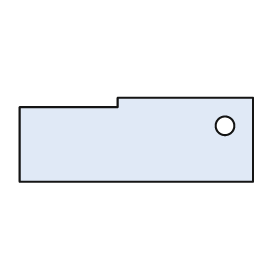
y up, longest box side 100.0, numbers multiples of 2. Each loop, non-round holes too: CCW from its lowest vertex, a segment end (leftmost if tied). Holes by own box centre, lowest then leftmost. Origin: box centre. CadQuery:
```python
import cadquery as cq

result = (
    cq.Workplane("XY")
    .moveTo(-50.0, -18.0)
    .lineTo(50.0, -18.0)
    .lineTo(50.0, 18.0)
    .lineTo(-8.0, 18.0)
    .lineTo(-8.0, 14.0)
    .lineTo(-50.0, 14.0)
    .close()
    .moveTo(38.0, 6.0)
    .circle(4.0)
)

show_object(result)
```